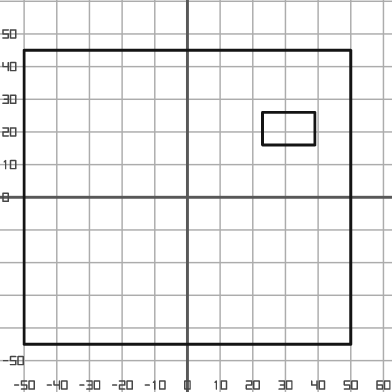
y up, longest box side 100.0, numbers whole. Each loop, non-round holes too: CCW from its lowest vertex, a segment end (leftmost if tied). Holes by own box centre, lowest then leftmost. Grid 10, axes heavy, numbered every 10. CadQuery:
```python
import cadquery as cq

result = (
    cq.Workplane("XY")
    .moveTo(-50.0, -45.0)
    .lineTo(50.0, -45.0)
    .lineTo(50.0, 45.0)
    .lineTo(-50.0, 45.0)
    .close()
    .moveTo(23.0, 16.0)
    .lineTo(39.0, 16.0)
    .lineTo(39.0, 26.0)
    .lineTo(23.0, 26.0)
    .close()
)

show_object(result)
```